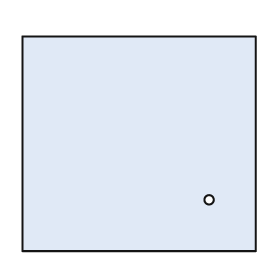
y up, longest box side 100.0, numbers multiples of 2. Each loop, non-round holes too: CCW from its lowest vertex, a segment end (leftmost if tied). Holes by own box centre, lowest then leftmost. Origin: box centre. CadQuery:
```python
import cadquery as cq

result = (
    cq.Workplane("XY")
    .moveTo(-50.0, -46.0)
    .lineTo(50.0, -46.0)
    .lineTo(50.0, 46.0)
    .lineTo(-50.0, 46.0)
    .close()
    .moveTo(30.0, -24.0)
    .circle(2.0)
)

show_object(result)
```